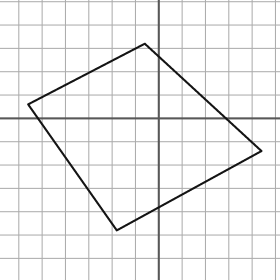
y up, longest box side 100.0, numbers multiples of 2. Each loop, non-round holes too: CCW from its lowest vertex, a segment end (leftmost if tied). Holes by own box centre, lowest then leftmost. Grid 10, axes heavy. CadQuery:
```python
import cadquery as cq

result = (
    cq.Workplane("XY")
    .moveTo(-18.0, -48.0)
    .lineTo(44.0, -14.0)
    .lineTo(-6.0, 32.0)
    .lineTo(-56.0, 6.0)
    .close()
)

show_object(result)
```